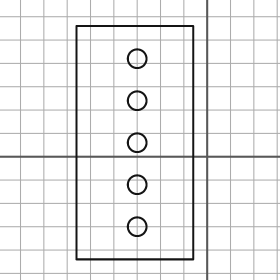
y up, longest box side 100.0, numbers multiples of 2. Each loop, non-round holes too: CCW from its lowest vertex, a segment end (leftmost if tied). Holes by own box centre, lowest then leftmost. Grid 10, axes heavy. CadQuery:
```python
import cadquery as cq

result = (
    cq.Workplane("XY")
    .moveTo(-56.0, -44.0)
    .lineTo(-6.0, -44.0)
    .lineTo(-6.0, 56.0)
    .lineTo(-56.0, 56.0)
    .close()
    .moveTo(-30.0, -30.0)
    .circle(4.0)
    .moveTo(-30.0, -12.0)
    .circle(4.0)
    .moveTo(-30.0, 6.0)
    .circle(4.0)
    .moveTo(-30.0, 24.0)
    .circle(4.0)
    .moveTo(-30.0, 42.0)
    .circle(4.0)
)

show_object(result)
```